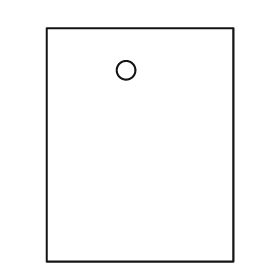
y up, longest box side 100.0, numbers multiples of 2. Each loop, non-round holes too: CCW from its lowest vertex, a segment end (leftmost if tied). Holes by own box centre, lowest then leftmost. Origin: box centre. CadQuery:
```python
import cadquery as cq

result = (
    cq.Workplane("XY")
    .moveTo(-40.0, -50.0)
    .lineTo(40.0, -50.0)
    .lineTo(40.0, 50.0)
    .lineTo(-40.0, 50.0)
    .close()
    .moveTo(-6.0, 32.0)
    .circle(4.0)
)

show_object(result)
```